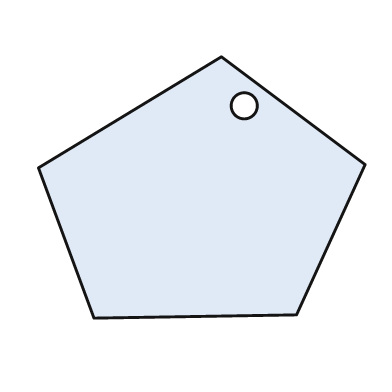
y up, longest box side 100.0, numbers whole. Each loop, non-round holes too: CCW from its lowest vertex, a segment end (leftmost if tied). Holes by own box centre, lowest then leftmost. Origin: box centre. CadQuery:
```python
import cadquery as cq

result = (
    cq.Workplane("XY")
    .moveTo(-33.0, -40.0)
    .lineTo(29.0, -39.0)
    .lineTo(50.0, 7.0)
    .lineTo(6.0, 40.0)
    .lineTo(-50.0, 6.0)
    .close()
    .moveTo(13.0, 25.0)
    .circle(4.0)
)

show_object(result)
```